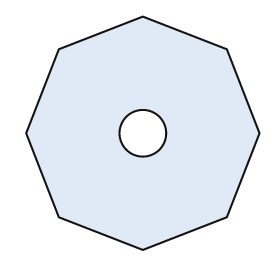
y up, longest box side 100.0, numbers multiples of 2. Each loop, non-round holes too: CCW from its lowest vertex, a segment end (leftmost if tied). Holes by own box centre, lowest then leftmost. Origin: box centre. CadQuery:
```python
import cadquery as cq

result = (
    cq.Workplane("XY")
    .moveTo(0.0, -50.0)
    .lineTo(36.0, -36.0)
    .lineTo(50.0, 0.0)
    .lineTo(36.0, 36.0)
    .lineTo(0.0, 50.0)
    .lineTo(-36.0, 36.0)
    .lineTo(-50.0, 0.0)
    .lineTo(-36.0, -36.0)
    .close()
    .moveTo(0.0, 0.0)
    .circle(10.0)
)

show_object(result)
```